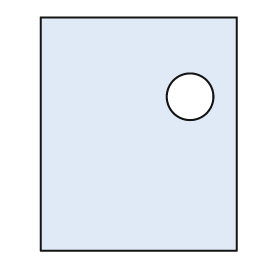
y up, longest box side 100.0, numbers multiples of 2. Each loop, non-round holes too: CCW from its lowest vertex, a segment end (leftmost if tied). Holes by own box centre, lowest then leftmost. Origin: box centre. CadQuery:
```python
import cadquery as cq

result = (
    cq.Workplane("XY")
    .moveTo(-42.0, -50.0)
    .lineTo(42.0, -50.0)
    .lineTo(42.0, 50.0)
    .lineTo(-42.0, 50.0)
    .close()
    .moveTo(22.0, 16.0)
    .circle(10.0)
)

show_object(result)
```